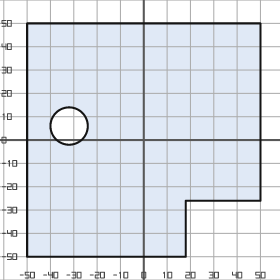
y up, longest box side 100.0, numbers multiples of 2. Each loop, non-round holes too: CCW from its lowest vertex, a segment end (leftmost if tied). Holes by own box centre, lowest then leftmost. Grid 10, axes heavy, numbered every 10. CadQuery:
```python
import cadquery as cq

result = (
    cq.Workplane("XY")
    .moveTo(-50.0, -50.0)
    .lineTo(18.0, -50.0)
    .lineTo(18.0, -26.0)
    .lineTo(50.0, -26.0)
    .lineTo(50.0, 50.0)
    .lineTo(-50.0, 50.0)
    .close()
    .moveTo(-32.0, 6.0)
    .circle(8.0)
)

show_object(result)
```